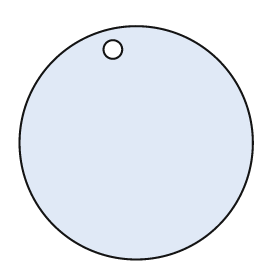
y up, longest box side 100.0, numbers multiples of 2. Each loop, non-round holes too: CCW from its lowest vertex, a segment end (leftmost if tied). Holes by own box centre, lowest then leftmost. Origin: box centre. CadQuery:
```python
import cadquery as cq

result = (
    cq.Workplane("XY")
    .moveTo(0.0, 0.0)
    .circle(50.0)
    .moveTo(-10.0, 40.0)
    .circle(4.0)
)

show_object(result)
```